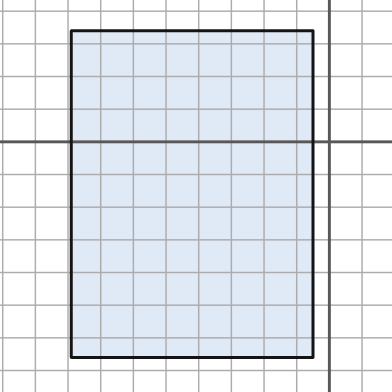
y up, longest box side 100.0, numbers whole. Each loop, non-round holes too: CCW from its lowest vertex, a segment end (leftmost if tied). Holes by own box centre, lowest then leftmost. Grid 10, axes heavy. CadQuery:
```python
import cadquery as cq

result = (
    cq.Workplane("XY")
    .moveTo(-79.0, -66.0)
    .lineTo(-5.0, -66.0)
    .lineTo(-5.0, 34.0)
    .lineTo(-79.0, 34.0)
    .close()
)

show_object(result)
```